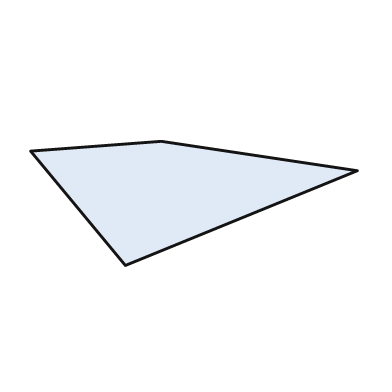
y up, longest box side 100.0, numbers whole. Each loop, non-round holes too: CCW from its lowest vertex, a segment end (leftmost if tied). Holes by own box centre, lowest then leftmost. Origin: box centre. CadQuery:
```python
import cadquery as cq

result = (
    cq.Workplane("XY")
    .moveTo(-21.0, -19.0)
    .lineTo(50.0, 10.0)
    .lineTo(-10.0, 19.0)
    .lineTo(-50.0, 16.0)
    .close()
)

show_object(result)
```